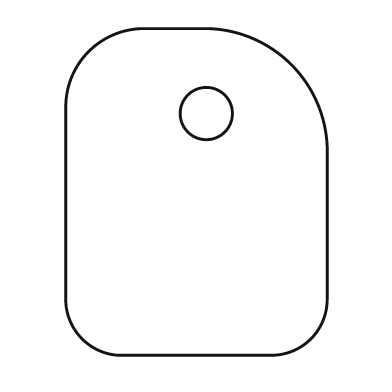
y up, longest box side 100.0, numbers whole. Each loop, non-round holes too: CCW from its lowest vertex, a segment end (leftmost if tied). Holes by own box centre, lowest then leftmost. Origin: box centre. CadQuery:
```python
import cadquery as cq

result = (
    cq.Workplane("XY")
    .moveTo(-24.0, -50.0)
    .lineTo(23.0, -50.0)
    .threePointArc((35.0, -45.0), (40.0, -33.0))
    .lineTo(40.0, 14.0)
    .threePointArc((29.0, 39.0), (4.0, 50.0))
    .lineTo(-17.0, 50.0)
    .threePointArc((-33.0, 43.0), (-40.0, 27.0))
    .lineTo(-40.0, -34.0)
    .threePointArc((-35.0, -45.0), (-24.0, -50.0))
    .close()
    .moveTo(3.0, 24.0)
    .circle(8.0)
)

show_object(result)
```